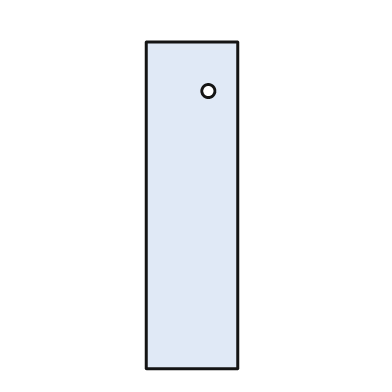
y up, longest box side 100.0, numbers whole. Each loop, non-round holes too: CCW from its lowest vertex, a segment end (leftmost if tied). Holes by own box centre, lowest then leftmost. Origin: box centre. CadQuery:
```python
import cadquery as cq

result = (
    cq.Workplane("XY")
    .moveTo(-14.0, -50.0)
    .lineTo(14.0, -50.0)
    .lineTo(14.0, 50.0)
    .lineTo(-14.0, 50.0)
    .close()
    .moveTo(5.0, 35.0)
    .circle(2.0)
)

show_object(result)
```